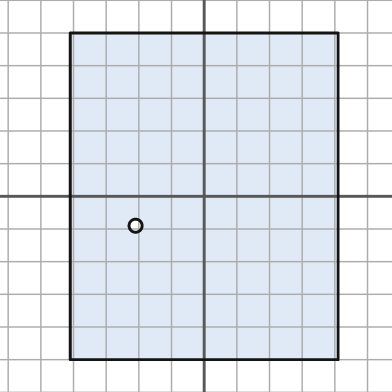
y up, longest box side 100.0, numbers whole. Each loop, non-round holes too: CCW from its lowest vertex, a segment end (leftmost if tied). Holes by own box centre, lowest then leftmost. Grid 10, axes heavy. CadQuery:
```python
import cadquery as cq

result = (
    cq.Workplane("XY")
    .moveTo(-41.0, -50.0)
    .lineTo(41.0, -50.0)
    .lineTo(41.0, 50.0)
    .lineTo(-41.0, 50.0)
    .close()
    .moveTo(-21.0, -9.0)
    .circle(2.0)
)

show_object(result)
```